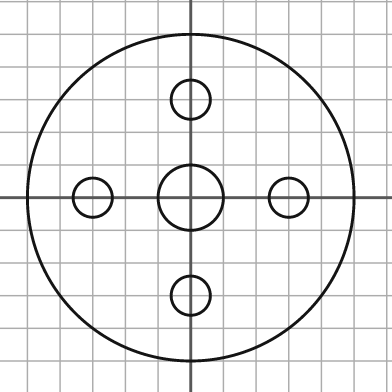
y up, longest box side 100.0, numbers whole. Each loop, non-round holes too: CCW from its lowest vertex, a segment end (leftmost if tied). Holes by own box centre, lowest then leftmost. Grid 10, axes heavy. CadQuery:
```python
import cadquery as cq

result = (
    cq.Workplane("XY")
    .moveTo(0.0, 0.0)
    .circle(50.0)
    .moveTo(0.0, -30.0)
    .circle(6.0)
    .moveTo(-30.0, 0.0)
    .circle(6.0)
    .moveTo(0.0, 0.0)
    .circle(10.0)
    .moveTo(30.0, 0.0)
    .circle(6.0)
    .moveTo(0.0, 30.0)
    .circle(6.0)
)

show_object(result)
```